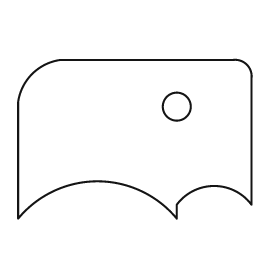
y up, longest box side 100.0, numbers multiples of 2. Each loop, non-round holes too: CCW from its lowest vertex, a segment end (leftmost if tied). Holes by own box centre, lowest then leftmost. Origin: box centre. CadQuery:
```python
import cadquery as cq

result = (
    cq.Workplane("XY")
    .moveTo(-50.0, -34.0)
    .threePointArc((-16.0, -18.0), (18.0, -34.0))
    .lineTo(18.0, -28.0)
    .threePointArc((34.0, -20.0), (50.0, -28.0))
    .lineTo(50.0, 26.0)
    .threePointArc((48.0, 32.0), (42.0, 34.0))
    .lineTo(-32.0, 34.0)
    .threePointArc((-44.0, 28.0), (-50.0, 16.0))
    .close()
    .moveTo(18.0, 14.0)
    .circle(6.0)
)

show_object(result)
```